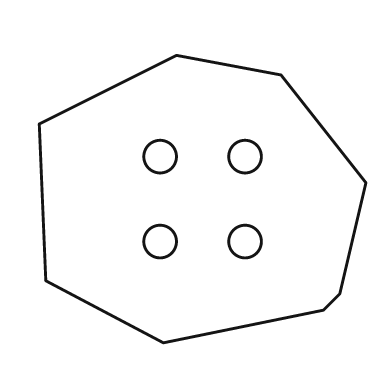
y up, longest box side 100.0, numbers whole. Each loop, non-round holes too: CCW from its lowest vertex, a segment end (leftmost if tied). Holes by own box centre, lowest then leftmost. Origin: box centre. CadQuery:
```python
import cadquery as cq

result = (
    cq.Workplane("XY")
    .moveTo(-12.0, -44.0)
    .lineTo(37.0, -34.0)
    .lineTo(42.0, -29.0)
    .lineTo(50.0, 5.0)
    .lineTo(24.0, 38.0)
    .lineTo(-8.0, 44.0)
    .lineTo(-50.0, 23.0)
    .lineTo(-48.0, -25.0)
    .close()
    .moveTo(-13.0, -13.0)
    .circle(5.0)
    .moveTo(13.0, -13.0)
    .circle(5.0)
    .moveTo(-13.0, 13.0)
    .circle(5.0)
    .moveTo(13.0, 13.0)
    .circle(5.0)
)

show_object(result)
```